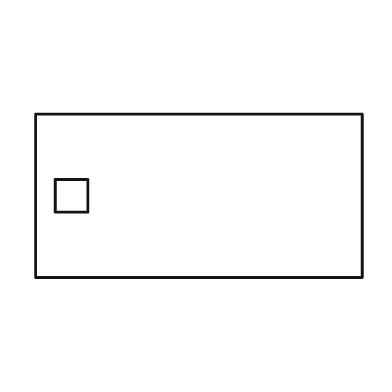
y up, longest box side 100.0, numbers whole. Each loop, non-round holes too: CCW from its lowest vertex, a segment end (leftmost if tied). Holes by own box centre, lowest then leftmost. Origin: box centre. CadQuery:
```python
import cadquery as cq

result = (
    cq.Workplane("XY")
    .moveTo(-50.0, -25.0)
    .lineTo(50.0, -25.0)
    .lineTo(50.0, 25.0)
    .lineTo(-50.0, 25.0)
    .close()
    .moveTo(-44.0, -5.0)
    .lineTo(-34.0, -5.0)
    .lineTo(-34.0, 5.0)
    .lineTo(-44.0, 5.0)
    .close()
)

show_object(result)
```